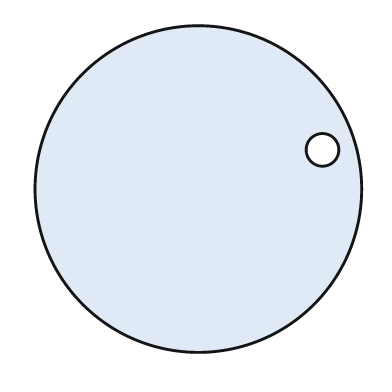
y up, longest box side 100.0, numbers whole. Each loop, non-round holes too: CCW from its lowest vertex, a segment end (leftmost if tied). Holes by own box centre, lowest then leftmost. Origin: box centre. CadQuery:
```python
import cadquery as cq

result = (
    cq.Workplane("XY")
    .moveTo(0.0, 0.0)
    .circle(50.0)
    .moveTo(38.0, 12.0)
    .circle(5.0)
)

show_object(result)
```